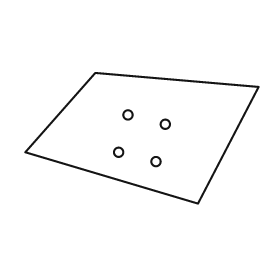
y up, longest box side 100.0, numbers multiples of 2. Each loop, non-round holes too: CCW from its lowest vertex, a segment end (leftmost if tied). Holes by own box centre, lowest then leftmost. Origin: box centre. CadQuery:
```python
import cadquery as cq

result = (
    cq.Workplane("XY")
    .moveTo(24.0, -28.0)
    .lineTo(50.0, 22.0)
    .lineTo(-20.0, 28.0)
    .lineTo(-50.0, -6.0)
    .close()
    .moveTo(6.0, -10.0)
    .circle(2.0)
    .moveTo(-10.0, -6.0)
    .circle(2.0)
    .moveTo(10.0, 6.0)
    .circle(2.0)
    .moveTo(-6.0, 10.0)
    .circle(2.0)
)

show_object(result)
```